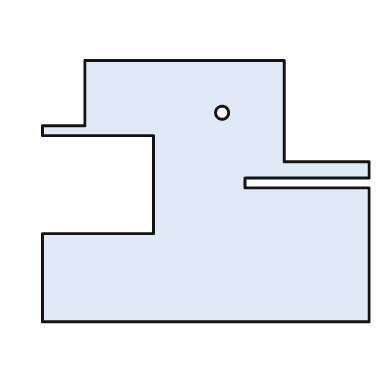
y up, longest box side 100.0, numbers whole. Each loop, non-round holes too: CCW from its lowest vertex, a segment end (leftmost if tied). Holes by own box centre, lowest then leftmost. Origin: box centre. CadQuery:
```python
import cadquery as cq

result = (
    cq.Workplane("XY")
    .moveTo(-50.0, -40.0)
    .lineTo(50.0, -40.0)
    .lineTo(50.0, 1.0)
    .lineTo(12.0, 1.0)
    .lineTo(12.0, 4.0)
    .lineTo(50.0, 4.0)
    .lineTo(50.0, 9.0)
    .lineTo(24.0, 9.0)
    .lineTo(24.0, 40.0)
    .lineTo(-37.0, 40.0)
    .lineTo(-37.0, 20.0)
    .lineTo(-50.0, 20.0)
    .lineTo(-50.0, 17.0)
    .lineTo(-16.0, 17.0)
    .lineTo(-16.0, -13.0)
    .lineTo(-50.0, -13.0)
    .close()
    .moveTo(5.0, 24.0)
    .circle(2.0)
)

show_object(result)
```